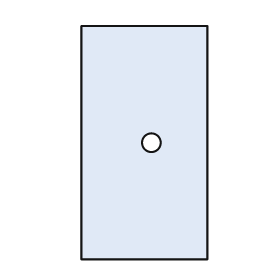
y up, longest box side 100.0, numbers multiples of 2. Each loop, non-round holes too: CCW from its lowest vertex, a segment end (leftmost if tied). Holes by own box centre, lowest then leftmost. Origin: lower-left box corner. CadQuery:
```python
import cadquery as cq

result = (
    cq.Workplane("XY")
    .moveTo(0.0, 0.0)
    .lineTo(54.0, 0.0)
    .lineTo(54.0, 100.0)
    .lineTo(0.0, 100.0)
    .close()
    .moveTo(30.0, 50.0)
    .circle(4.0)
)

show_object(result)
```